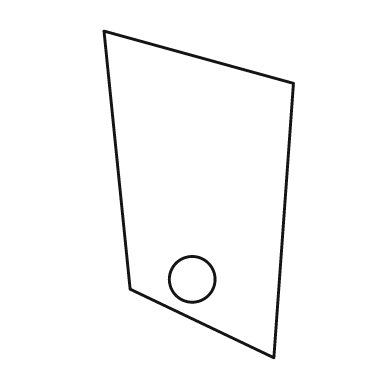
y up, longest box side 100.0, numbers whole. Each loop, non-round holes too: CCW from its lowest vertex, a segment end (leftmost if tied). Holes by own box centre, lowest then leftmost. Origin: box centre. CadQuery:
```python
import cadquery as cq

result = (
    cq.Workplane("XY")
    .moveTo(23.0, -50.0)
    .lineTo(29.0, 34.0)
    .lineTo(-29.0, 50.0)
    .lineTo(-21.0, -29.0)
    .close()
    .moveTo(-2.0, -26.0)
    .circle(7.0)
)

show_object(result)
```